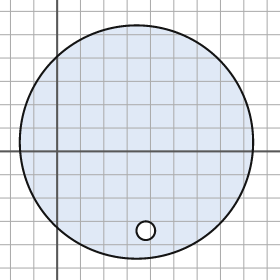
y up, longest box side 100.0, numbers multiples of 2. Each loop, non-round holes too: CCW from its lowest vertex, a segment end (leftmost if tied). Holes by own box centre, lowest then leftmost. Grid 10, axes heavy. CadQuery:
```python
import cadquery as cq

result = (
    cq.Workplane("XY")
    .moveTo(34.0, 4.0)
    .circle(50.0)
    .moveTo(38.0, -34.0)
    .circle(4.0)
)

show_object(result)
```